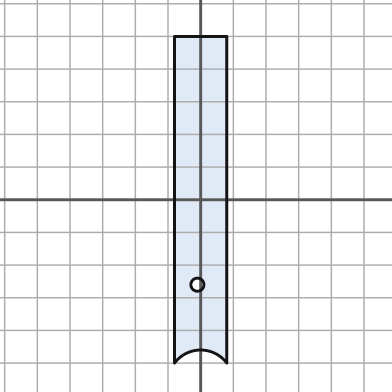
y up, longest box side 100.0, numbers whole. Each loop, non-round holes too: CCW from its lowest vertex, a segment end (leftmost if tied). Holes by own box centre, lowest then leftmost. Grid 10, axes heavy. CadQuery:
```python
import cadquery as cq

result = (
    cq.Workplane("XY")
    .moveTo(-8.0, -50.0)
    .threePointArc((0.0, -46.0), (8.0, -50.0))
    .lineTo(8.0, 50.0)
    .lineTo(-8.0, 50.0)
    .close()
    .moveTo(-1.0, -26.0)
    .circle(2.0)
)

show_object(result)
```